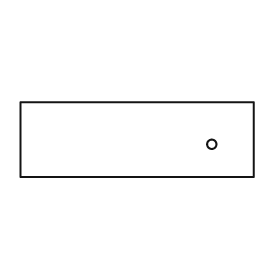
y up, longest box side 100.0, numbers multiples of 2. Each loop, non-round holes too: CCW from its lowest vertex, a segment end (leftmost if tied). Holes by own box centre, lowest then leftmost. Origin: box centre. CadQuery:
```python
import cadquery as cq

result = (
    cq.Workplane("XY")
    .moveTo(-50.0, -16.0)
    .lineTo(50.0, -16.0)
    .lineTo(50.0, 16.0)
    .lineTo(-50.0, 16.0)
    .close()
    .moveTo(32.0, -2.0)
    .circle(2.0)
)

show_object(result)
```